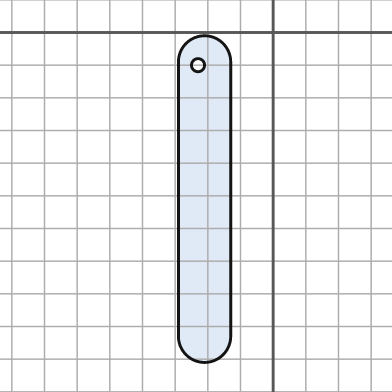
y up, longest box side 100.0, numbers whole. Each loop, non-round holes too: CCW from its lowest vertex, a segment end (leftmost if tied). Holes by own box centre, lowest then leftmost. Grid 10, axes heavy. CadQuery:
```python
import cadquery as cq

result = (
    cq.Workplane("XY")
    .moveTo(-29.0, -93.0)
    .threePointArc((-21.0, -101.0), (-13.0, -93.0))
    .lineTo(-13.0, -9.0)
    .threePointArc((-21.0, -1.0), (-29.0, -9.0))
    .close()
    .moveTo(-23.0, -10.0)
    .circle(2.0)
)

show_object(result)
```